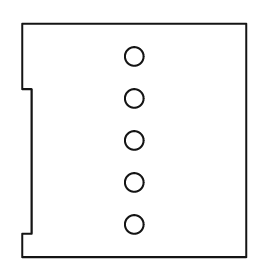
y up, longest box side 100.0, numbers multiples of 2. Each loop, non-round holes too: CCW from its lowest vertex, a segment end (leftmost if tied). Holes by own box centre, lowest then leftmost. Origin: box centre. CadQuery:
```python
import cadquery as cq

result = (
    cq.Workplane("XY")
    .moveTo(-48.0, -50.0)
    .lineTo(48.0, -50.0)
    .lineTo(48.0, 50.0)
    .lineTo(-48.0, 50.0)
    .lineTo(-48.0, 22.0)
    .lineTo(-44.0, 22.0)
    .lineTo(-44.0, -40.0)
    .lineTo(-48.0, -40.0)
    .close()
    .moveTo(0.0, -36.0)
    .circle(4.0)
    .moveTo(0.0, -18.0)
    .circle(4.0)
    .moveTo(0.0, 0.0)
    .circle(4.0)
    .moveTo(0.0, 18.0)
    .circle(4.0)
    .moveTo(0.0, 36.0)
    .circle(4.0)
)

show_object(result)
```